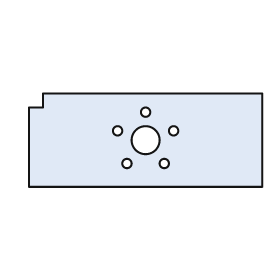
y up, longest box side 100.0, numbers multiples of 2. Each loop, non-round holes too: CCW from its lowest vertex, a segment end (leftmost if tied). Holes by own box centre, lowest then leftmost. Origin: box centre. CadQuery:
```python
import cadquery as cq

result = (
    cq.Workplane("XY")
    .moveTo(-50.0, -20.0)
    .lineTo(50.0, -20.0)
    .lineTo(50.0, 20.0)
    .lineTo(-44.0, 20.0)
    .lineTo(-44.0, 14.0)
    .lineTo(-50.0, 14.0)
    .close()
    .moveTo(-8.0, -10.0)
    .circle(2.0)
    .moveTo(8.0, -10.0)
    .circle(2.0)
    .moveTo(0.0, 0.0)
    .circle(6.0)
    .moveTo(-12.0, 4.0)
    .circle(2.0)
    .moveTo(12.0, 4.0)
    .circle(2.0)
    .moveTo(0.0, 12.0)
    .circle(2.0)
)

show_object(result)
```